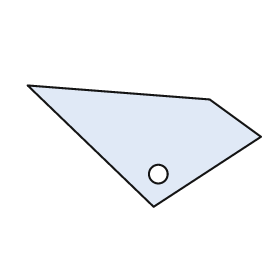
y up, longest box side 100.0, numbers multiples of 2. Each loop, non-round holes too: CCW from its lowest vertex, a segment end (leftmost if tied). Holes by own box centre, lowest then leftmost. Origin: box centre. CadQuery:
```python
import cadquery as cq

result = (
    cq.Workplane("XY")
    .moveTo(4.0, -26.0)
    .lineTo(50.0, 4.0)
    .lineTo(28.0, 20.0)
    .lineTo(-50.0, 26.0)
    .close()
    .moveTo(6.0, -12.0)
    .circle(4.0)
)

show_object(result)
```